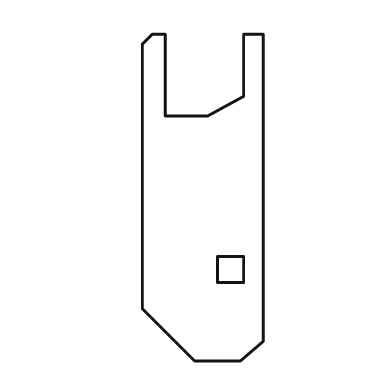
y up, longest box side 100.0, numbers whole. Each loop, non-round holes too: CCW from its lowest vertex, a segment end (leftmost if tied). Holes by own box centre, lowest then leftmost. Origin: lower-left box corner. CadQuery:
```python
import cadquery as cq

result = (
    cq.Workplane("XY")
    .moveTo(16.0, 0.0)
    .lineTo(30.0, 0.0)
    .lineTo(37.0, 6.0)
    .lineTo(37.0, 100.0)
    .lineTo(31.0, 100.0)
    .lineTo(31.0, 81.0)
    .lineTo(20.0, 75.0)
    .lineTo(7.0, 75.0)
    .lineTo(7.0, 100.0)
    .lineTo(3.0, 100.0)
    .lineTo(0.0, 97.0)
    .lineTo(0.0, 16.0)
    .close()
    .moveTo(23.0, 24.0)
    .lineTo(31.0, 24.0)
    .lineTo(31.0, 32.0)
    .lineTo(23.0, 32.0)
    .close()
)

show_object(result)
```